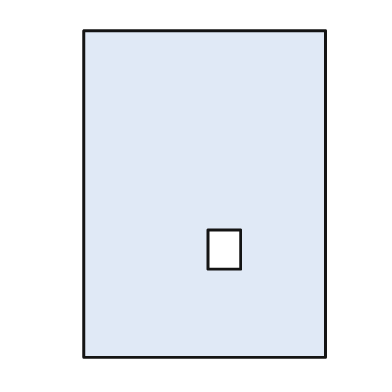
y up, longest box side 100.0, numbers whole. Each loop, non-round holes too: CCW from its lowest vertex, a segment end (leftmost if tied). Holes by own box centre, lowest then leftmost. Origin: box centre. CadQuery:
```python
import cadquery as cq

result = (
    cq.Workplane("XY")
    .moveTo(-37.0, -50.0)
    .lineTo(37.0, -50.0)
    .lineTo(37.0, 50.0)
    .lineTo(-37.0, 50.0)
    .close()
    .moveTo(1.0, -23.0)
    .lineTo(11.0, -23.0)
    .lineTo(11.0, -11.0)
    .lineTo(1.0, -11.0)
    .close()
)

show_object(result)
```